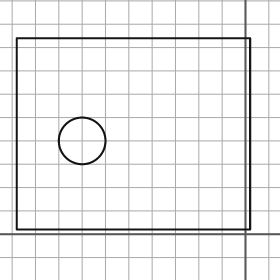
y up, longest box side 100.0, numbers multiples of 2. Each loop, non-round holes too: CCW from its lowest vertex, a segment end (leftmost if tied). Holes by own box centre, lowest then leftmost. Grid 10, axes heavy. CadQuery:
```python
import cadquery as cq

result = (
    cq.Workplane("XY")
    .moveTo(-98.0, 2.0)
    .lineTo(2.0, 2.0)
    .lineTo(2.0, 84.0)
    .lineTo(-98.0, 84.0)
    .close()
    .moveTo(-70.0, 40.0)
    .circle(10.0)
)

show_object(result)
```